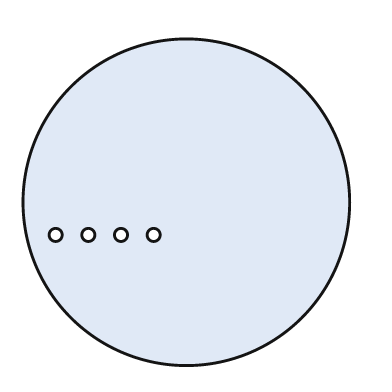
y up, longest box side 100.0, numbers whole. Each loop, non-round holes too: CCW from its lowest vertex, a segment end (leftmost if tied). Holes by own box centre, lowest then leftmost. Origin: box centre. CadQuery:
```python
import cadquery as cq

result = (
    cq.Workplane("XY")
    .moveTo(0.0, 0.0)
    .circle(50.0)
    .moveTo(-40.0, -10.0)
    .circle(2.0)
    .moveTo(-30.0, -10.0)
    .circle(2.0)
    .moveTo(-20.0, -10.0)
    .circle(2.0)
    .moveTo(-10.0, -10.0)
    .circle(2.0)
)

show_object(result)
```